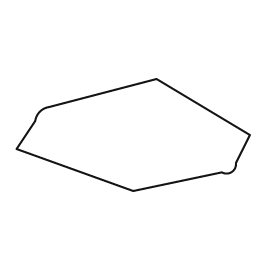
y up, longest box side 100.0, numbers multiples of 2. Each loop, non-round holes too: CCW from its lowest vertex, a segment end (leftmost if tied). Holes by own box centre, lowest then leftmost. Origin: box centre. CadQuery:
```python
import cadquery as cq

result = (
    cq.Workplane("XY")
    .moveTo(0.0, -24.0)
    .lineTo(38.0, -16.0)
    .threePointArc((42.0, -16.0), (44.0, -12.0))
    .lineTo(50.0, 0.0)
    .lineTo(10.0, 24.0)
    .lineTo(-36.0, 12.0)
    .threePointArc((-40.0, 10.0), (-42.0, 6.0))
    .lineTo(-50.0, -6.0)
    .close()
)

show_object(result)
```